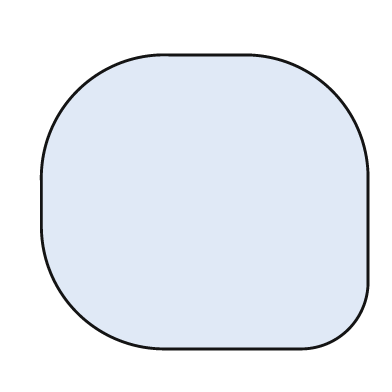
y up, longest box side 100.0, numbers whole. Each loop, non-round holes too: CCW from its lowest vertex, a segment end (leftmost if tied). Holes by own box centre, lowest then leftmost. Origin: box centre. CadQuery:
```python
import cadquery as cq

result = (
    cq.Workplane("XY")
    .moveTo(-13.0, -45.0)
    .lineTo(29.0, -45.0)
    .threePointArc((44.0, -39.0), (50.0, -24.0))
    .lineTo(50.0, 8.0)
    .threePointArc((39.0, 34.0), (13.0, 45.0))
    .lineTo(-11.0, 45.0)
    .threePointArc((-39.0, 34.0), (-50.0, 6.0))
    .lineTo(-50.0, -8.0)
    .threePointArc((-39.0, -34.0), (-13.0, -45.0))
    .close()
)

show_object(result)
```